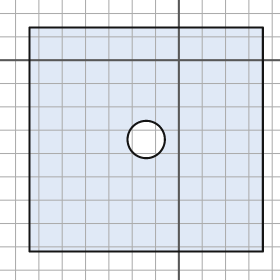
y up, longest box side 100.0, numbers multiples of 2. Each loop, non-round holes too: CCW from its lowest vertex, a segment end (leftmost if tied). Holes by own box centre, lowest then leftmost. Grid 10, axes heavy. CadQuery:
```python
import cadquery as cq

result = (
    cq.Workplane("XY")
    .moveTo(-64.0, -82.0)
    .lineTo(36.0, -82.0)
    .lineTo(36.0, 14.0)
    .lineTo(-64.0, 14.0)
    .close()
    .moveTo(-14.0, -34.0)
    .circle(8.0)
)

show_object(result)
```